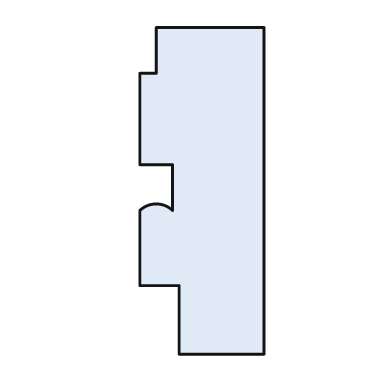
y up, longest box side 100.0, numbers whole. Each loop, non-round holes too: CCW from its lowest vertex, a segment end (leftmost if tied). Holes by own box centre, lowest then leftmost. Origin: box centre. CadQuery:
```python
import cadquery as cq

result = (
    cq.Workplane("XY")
    .moveTo(-7.0, -50.0)
    .lineTo(19.0, -50.0)
    .lineTo(19.0, 50.0)
    .lineTo(-14.0, 50.0)
    .lineTo(-14.0, 36.0)
    .lineTo(-19.0, 36.0)
    .lineTo(-19.0, 8.0)
    .lineTo(-9.0, 8.0)
    .lineTo(-9.0, -6.0)
    .threePointArc((-14.0, -4.0), (-19.0, -6.0))
    .lineTo(-19.0, -29.0)
    .lineTo(-7.0, -29.0)
    .close()
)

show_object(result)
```